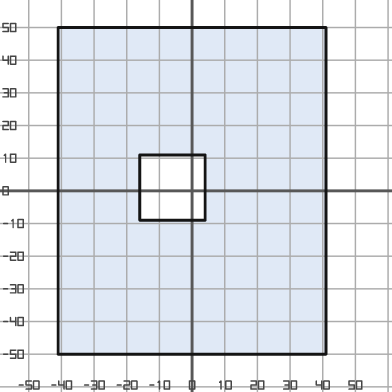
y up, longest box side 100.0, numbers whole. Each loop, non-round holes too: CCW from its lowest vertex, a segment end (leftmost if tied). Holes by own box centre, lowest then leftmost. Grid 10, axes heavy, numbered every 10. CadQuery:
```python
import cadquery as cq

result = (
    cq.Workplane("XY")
    .moveTo(-41.0, -50.0)
    .lineTo(41.0, -50.0)
    .lineTo(41.0, 50.0)
    .lineTo(-41.0, 50.0)
    .close()
    .moveTo(-16.0, -9.0)
    .lineTo(4.0, -9.0)
    .lineTo(4.0, 11.0)
    .lineTo(-16.0, 11.0)
    .close()
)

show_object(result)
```